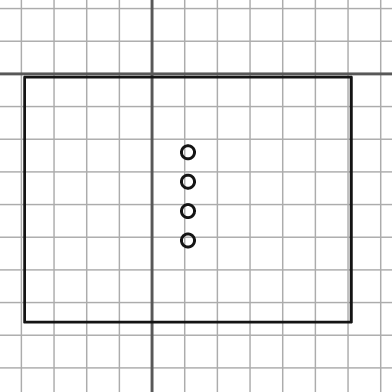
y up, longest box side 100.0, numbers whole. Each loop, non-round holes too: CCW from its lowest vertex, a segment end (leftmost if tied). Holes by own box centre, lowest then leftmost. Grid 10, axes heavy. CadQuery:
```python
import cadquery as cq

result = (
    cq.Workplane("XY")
    .moveTo(-39.0, -76.0)
    .lineTo(61.0, -76.0)
    .lineTo(61.0, -1.0)
    .lineTo(-39.0, -1.0)
    .close()
    .moveTo(11.0, -51.0)
    .circle(2.0)
    .moveTo(11.0, -42.0)
    .circle(2.0)
    .moveTo(11.0, -33.0)
    .circle(2.0)
    .moveTo(11.0, -24.0)
    .circle(2.0)
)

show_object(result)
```